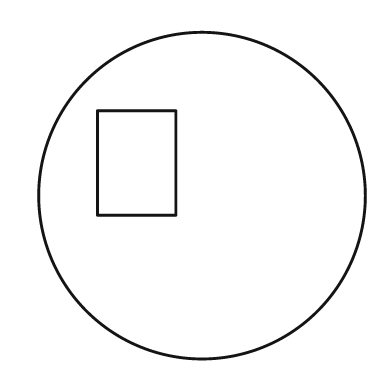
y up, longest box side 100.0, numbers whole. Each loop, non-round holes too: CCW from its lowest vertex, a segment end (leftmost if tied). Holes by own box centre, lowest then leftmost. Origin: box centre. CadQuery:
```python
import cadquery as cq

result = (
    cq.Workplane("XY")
    .moveTo(0.0, 0.0)
    .circle(50.0)
    .moveTo(-32.0, -6.0)
    .lineTo(-8.0, -6.0)
    .lineTo(-8.0, 26.0)
    .lineTo(-32.0, 26.0)
    .close()
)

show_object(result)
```